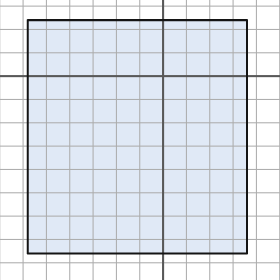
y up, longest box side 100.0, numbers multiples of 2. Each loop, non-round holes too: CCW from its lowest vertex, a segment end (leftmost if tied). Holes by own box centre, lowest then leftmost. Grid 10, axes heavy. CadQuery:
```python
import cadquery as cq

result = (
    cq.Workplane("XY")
    .moveTo(-58.0, -76.0)
    .lineTo(36.0, -76.0)
    .lineTo(36.0, 24.0)
    .lineTo(-58.0, 24.0)
    .close()
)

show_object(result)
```